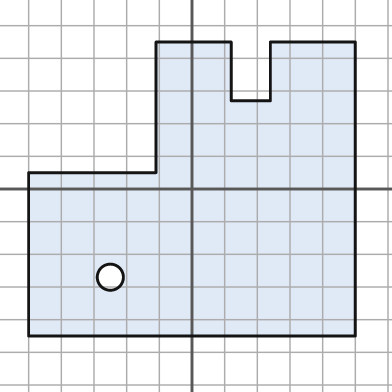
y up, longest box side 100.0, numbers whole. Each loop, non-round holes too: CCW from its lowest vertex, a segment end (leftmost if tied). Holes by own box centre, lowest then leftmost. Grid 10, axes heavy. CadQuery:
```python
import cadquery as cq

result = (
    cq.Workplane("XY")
    .moveTo(-50.0, -45.0)
    .lineTo(50.0, -45.0)
    .lineTo(50.0, 45.0)
    .lineTo(24.0, 45.0)
    .lineTo(24.0, 27.0)
    .lineTo(12.0, 27.0)
    .lineTo(12.0, 45.0)
    .lineTo(-11.0, 45.0)
    .lineTo(-11.0, 5.0)
    .lineTo(-50.0, 5.0)
    .close()
    .moveTo(-25.0, -27.0)
    .circle(4.0)
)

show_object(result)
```